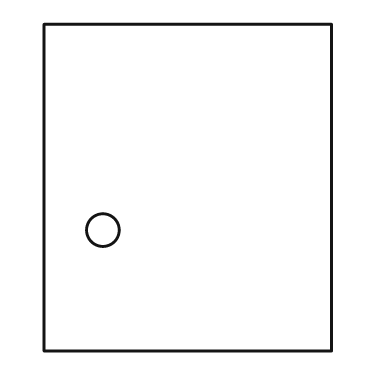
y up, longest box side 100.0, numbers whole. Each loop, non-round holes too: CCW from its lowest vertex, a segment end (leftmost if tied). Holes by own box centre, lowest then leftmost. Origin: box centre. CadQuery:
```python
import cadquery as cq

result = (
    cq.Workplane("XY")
    .moveTo(-44.0, -50.0)
    .lineTo(44.0, -50.0)
    .lineTo(44.0, 50.0)
    .lineTo(-44.0, 50.0)
    .close()
    .moveTo(-26.0, -13.0)
    .circle(5.0)
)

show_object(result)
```